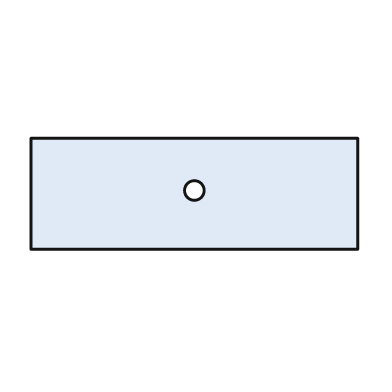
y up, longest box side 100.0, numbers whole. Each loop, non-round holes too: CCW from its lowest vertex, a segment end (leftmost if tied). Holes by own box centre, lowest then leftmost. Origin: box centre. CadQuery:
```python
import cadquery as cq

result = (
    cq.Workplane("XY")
    .moveTo(-50.0, -17.0)
    .lineTo(50.0, -17.0)
    .lineTo(50.0, 17.0)
    .lineTo(-50.0, 17.0)
    .close()
    .moveTo(0.0, 1.0)
    .circle(3.0)
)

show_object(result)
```